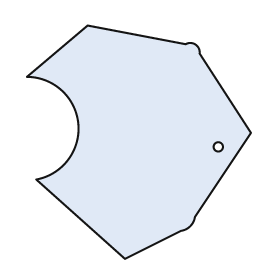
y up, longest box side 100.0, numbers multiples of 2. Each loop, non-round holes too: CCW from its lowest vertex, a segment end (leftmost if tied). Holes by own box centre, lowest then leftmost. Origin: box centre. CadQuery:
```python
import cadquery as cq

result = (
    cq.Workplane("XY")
    .moveTo(-6.0, -50.0)
    .lineTo(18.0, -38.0)
    .threePointArc((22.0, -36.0), (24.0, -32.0))
    .lineTo(48.0, 4.0)
    .lineTo(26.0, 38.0)
    .threePointArc((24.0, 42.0), (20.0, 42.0))
    .lineTo(-22.0, 50.0)
    .lineTo(-48.0, 28.0)
    .threePointArc((-26.0, 8.0), (-44.0, -16.0))
    .close()
    .moveTo(34.0, -2.0)
    .circle(2.0)
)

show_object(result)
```